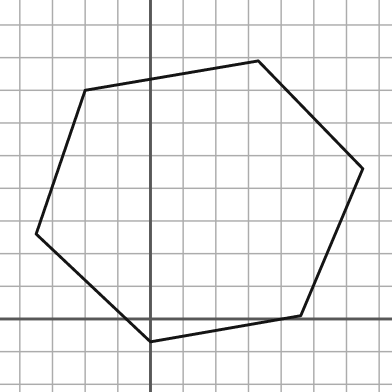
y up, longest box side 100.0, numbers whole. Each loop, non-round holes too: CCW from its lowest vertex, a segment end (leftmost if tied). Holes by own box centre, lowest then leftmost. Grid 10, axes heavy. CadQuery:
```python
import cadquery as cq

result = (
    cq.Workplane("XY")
    .moveTo(0.0, -7.0)
    .lineTo(46.0, 1.0)
    .lineTo(65.0, 46.0)
    .lineTo(33.0, 79.0)
    .lineTo(-20.0, 70.0)
    .lineTo(-35.0, 26.0)
    .close()
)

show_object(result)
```